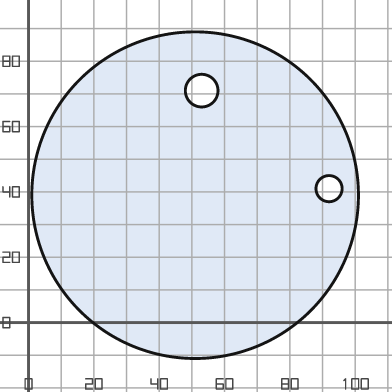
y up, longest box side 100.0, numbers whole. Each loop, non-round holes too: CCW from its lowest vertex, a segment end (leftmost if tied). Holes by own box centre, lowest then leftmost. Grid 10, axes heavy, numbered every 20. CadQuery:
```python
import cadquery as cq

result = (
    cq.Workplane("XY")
    .moveTo(51.0, 39.0)
    .circle(50.0)
    .moveTo(92.0, 41.0)
    .circle(4.0)
    .moveTo(53.0, 71.0)
    .circle(5.0)
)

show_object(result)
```